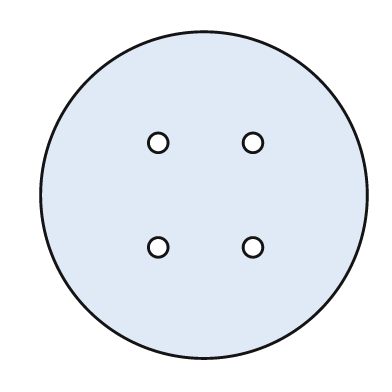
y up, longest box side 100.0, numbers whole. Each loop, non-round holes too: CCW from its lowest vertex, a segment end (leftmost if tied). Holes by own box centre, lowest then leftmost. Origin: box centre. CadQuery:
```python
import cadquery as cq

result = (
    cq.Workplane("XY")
    .moveTo(0.0, 0.0)
    .circle(50.0)
    .moveTo(-14.0, -16.0)
    .circle(3.0)
    .moveTo(15.0, -16.0)
    .circle(3.0)
    .moveTo(-14.0, 16.0)
    .circle(3.0)
    .moveTo(15.0, 16.0)
    .circle(3.0)
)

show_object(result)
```